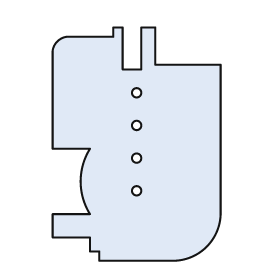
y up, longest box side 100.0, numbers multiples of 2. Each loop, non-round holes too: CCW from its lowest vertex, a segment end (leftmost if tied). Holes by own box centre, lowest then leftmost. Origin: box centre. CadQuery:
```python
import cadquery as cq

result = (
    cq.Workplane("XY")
    .moveTo(-16.0, -50.0)
    .lineTo(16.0, -50.0)
    .threePointArc((30.0, -44.0), (36.0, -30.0))
    .lineTo(36.0, 34.0)
    .lineTo(8.0, 34.0)
    .lineTo(8.0, 50.0)
    .lineTo(2.0, 50.0)
    .lineTo(2.0, 32.0)
    .lineTo(-6.0, 32.0)
    .lineTo(-6.0, 50.0)
    .lineTo(-10.0, 50.0)
    .lineTo(-10.0, 46.0)
    .lineTo(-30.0, 46.0)
    .threePointArc((-34.0, 44.0), (-36.0, 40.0))
    .lineTo(-36.0, -2.0)
    .lineTo(-20.0, -2.0)
    .threePointArc((-24.0, -16.0), (-20.0, -30.0))
    .lineTo(-36.0, -30.0)
    .lineTo(-36.0, -40.0)
    .lineTo(-20.0, -40.0)
    .lineTo(-20.0, -46.0)
    .lineTo(-16.0, -46.0)
    .close()
    .moveTo(0.0, -20.0)
    .circle(2.0)
    .moveTo(0.0, -6.0)
    .circle(2.0)
    .moveTo(0.0, 8.0)
    .circle(2.0)
    .moveTo(0.0, 22.0)
    .circle(2.0)
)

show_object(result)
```